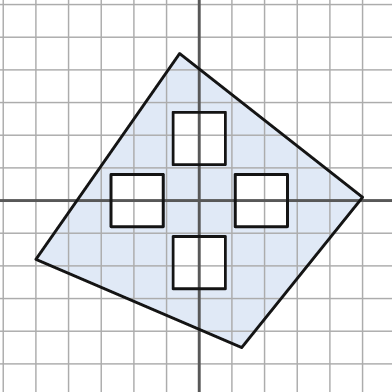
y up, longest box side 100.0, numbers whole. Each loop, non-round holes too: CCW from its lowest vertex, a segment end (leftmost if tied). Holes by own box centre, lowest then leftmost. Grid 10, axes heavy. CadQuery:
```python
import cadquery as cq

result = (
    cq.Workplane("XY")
    .moveTo(13.0, -45.0)
    .lineTo(50.0, 1.0)
    .lineTo(-6.0, 45.0)
    .lineTo(-50.0, -18.0)
    .close()
    .moveTo(-8.0, -27.0)
    .lineTo(8.0, -27.0)
    .lineTo(8.0, -11.0)
    .lineTo(-8.0, -11.0)
    .close()
    .moveTo(-27.0, -8.0)
    .lineTo(-11.0, -8.0)
    .lineTo(-11.0, 8.0)
    .lineTo(-27.0, 8.0)
    .close()
    .moveTo(11.0, -8.0)
    .lineTo(27.0, -8.0)
    .lineTo(27.0, 8.0)
    .lineTo(11.0, 8.0)
    .close()
    .moveTo(-8.0, 11.0)
    .lineTo(8.0, 11.0)
    .lineTo(8.0, 27.0)
    .lineTo(-8.0, 27.0)
    .close()
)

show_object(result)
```